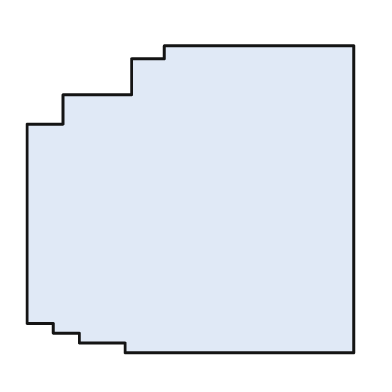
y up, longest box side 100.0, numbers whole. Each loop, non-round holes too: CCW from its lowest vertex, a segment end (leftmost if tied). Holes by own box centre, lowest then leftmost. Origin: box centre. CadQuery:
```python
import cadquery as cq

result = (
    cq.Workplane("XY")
    .moveTo(-20.0, -47.0)
    .lineTo(50.0, -47.0)
    .lineTo(50.0, 47.0)
    .lineTo(-8.0, 47.0)
    .lineTo(-8.0, 43.0)
    .lineTo(-18.0, 43.0)
    .lineTo(-18.0, 32.0)
    .lineTo(-39.0, 32.0)
    .lineTo(-39.0, 23.0)
    .lineTo(-50.0, 23.0)
    .lineTo(-50.0, -38.0)
    .lineTo(-42.0, -38.0)
    .lineTo(-42.0, -41.0)
    .lineTo(-34.0, -41.0)
    .lineTo(-34.0, -44.0)
    .lineTo(-20.0, -44.0)
    .close()
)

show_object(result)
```